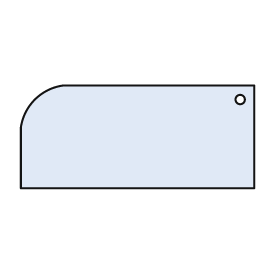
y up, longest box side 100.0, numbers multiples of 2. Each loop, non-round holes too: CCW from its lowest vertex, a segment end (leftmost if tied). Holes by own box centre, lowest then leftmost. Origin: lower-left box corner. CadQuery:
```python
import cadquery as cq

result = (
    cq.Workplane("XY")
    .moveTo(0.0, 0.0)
    .lineTo(100.0, 0.0)
    .lineTo(100.0, 44.0)
    .lineTo(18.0, 44.0)
    .threePointArc((6.0, 38.0), (0.0, 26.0))
    .close()
    .moveTo(94.0, 38.0)
    .circle(2.0)
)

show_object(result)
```